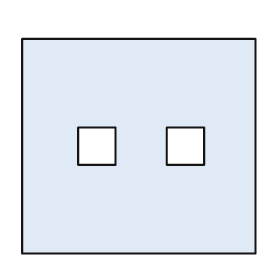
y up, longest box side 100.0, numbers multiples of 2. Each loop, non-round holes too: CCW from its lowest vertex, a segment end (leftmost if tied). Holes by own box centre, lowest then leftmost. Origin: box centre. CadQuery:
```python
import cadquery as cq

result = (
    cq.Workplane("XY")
    .moveTo(-50.0, -46.0)
    .lineTo(50.0, -46.0)
    .lineTo(50.0, 46.0)
    .lineTo(-50.0, 46.0)
    .close()
    .moveTo(-26.0, -8.0)
    .lineTo(-10.0, -8.0)
    .lineTo(-10.0, 8.0)
    .lineTo(-26.0, 8.0)
    .close()
    .moveTo(12.0, -8.0)
    .lineTo(28.0, -8.0)
    .lineTo(28.0, 8.0)
    .lineTo(12.0, 8.0)
    .close()
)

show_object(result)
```